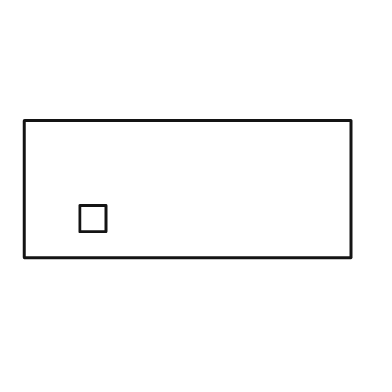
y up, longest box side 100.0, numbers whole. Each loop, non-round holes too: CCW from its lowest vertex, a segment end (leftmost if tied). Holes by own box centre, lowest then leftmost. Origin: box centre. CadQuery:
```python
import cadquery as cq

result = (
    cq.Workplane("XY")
    .moveTo(-50.0, -21.0)
    .lineTo(50.0, -21.0)
    .lineTo(50.0, 21.0)
    .lineTo(-50.0, 21.0)
    .close()
    .moveTo(-33.0, -13.0)
    .lineTo(-25.0, -13.0)
    .lineTo(-25.0, -5.0)
    .lineTo(-33.0, -5.0)
    .close()
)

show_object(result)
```